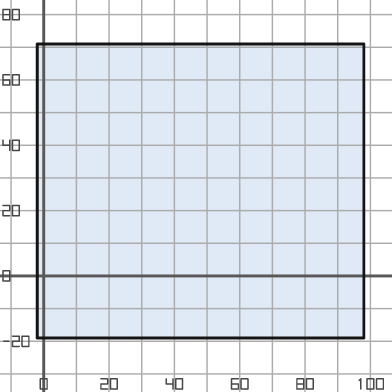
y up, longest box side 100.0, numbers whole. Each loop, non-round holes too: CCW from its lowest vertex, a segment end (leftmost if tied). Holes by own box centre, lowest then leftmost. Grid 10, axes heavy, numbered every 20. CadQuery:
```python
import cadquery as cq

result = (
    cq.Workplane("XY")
    .moveTo(-2.0, -19.0)
    .lineTo(98.0, -19.0)
    .lineTo(98.0, 71.0)
    .lineTo(-2.0, 71.0)
    .close()
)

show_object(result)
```